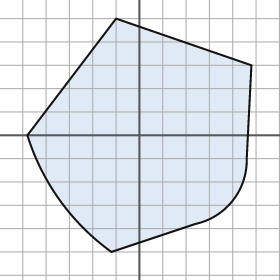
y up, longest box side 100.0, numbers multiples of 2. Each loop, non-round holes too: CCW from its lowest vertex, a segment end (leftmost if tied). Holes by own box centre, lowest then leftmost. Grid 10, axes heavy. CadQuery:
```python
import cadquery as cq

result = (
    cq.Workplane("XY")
    .moveTo(-12.0, -50.0)
    .lineTo(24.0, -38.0)
    .threePointArc((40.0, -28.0), (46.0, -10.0))
    .lineTo(48.0, 30.0)
    .lineTo(-10.0, 50.0)
    .lineTo(-48.0, 0.0)
    .threePointArc((-34.0, -28.0), (-12.0, -50.0))
    .close()
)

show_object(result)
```